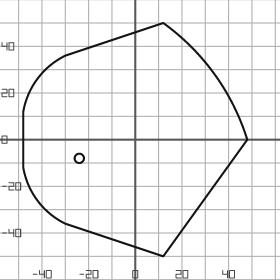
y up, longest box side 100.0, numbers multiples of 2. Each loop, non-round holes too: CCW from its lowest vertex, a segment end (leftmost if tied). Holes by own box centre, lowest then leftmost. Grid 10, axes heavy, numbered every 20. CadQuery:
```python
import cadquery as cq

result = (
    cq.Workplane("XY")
    .moveTo(12.0, -50.0)
    .lineTo(48.0, 0.0)
    .threePointArc((34.0, 28.0), (12.0, 50.0))
    .lineTo(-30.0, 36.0)
    .threePointArc((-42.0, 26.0), (-48.0, 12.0))
    .lineTo(-48.0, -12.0)
    .threePointArc((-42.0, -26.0), (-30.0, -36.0))
    .close()
    .moveTo(-24.0, -8.0)
    .circle(2.0)
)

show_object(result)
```